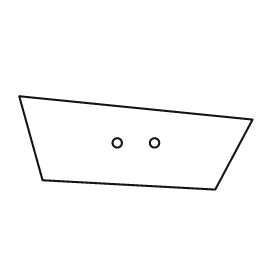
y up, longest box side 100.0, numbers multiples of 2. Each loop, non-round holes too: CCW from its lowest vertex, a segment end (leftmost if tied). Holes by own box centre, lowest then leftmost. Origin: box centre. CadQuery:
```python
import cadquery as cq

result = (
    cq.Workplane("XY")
    .moveTo(34.0, -20.0)
    .lineTo(50.0, 10.0)
    .lineTo(-50.0, 20.0)
    .lineTo(-40.0, -16.0)
    .close()
    .moveTo(-8.0, 0.0)
    .circle(2.0)
    .moveTo(8.0, 0.0)
    .circle(2.0)
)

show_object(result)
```